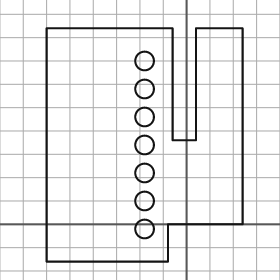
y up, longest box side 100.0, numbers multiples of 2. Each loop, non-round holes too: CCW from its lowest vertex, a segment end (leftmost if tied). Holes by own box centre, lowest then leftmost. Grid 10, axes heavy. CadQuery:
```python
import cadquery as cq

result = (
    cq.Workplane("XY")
    .moveTo(-60.0, -16.0)
    .lineTo(-8.0, -16.0)
    .lineTo(-8.0, 0.0)
    .lineTo(24.0, 0.0)
    .lineTo(24.0, 84.0)
    .lineTo(4.0, 84.0)
    .lineTo(4.0, 36.0)
    .lineTo(-6.0, 36.0)
    .lineTo(-6.0, 84.0)
    .lineTo(-60.0, 84.0)
    .close()
    .moveTo(-18.0, -2.0)
    .circle(4.0)
    .moveTo(-18.0, 10.0)
    .circle(4.0)
    .moveTo(-18.0, 22.0)
    .circle(4.0)
    .moveTo(-18.0, 34.0)
    .circle(4.0)
    .moveTo(-18.0, 46.0)
    .circle(4.0)
    .moveTo(-18.0, 58.0)
    .circle(4.0)
    .moveTo(-18.0, 70.0)
    .circle(4.0)
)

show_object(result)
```